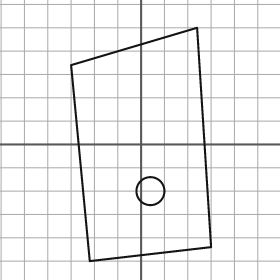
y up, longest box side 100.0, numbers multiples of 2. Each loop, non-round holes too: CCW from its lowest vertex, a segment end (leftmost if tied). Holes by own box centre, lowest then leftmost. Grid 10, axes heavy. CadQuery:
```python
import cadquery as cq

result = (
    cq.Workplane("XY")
    .moveTo(-22.0, -50.0)
    .lineTo(30.0, -44.0)
    .lineTo(24.0, 50.0)
    .lineTo(-30.0, 34.0)
    .close()
    .moveTo(4.0, -20.0)
    .circle(6.0)
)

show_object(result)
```